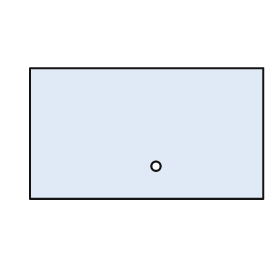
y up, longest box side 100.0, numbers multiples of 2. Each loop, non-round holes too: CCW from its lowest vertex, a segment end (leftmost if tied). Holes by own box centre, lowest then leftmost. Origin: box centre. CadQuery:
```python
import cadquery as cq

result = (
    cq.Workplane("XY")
    .moveTo(-50.0, -28.0)
    .lineTo(50.0, -28.0)
    .lineTo(50.0, 28.0)
    .lineTo(-50.0, 28.0)
    .close()
    .moveTo(4.0, -14.0)
    .circle(2.0)
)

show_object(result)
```